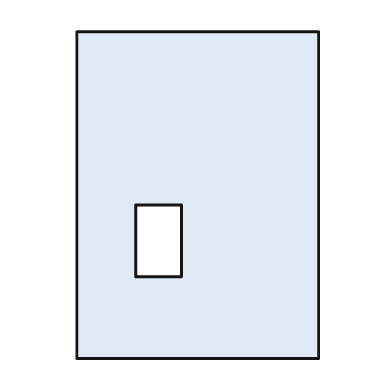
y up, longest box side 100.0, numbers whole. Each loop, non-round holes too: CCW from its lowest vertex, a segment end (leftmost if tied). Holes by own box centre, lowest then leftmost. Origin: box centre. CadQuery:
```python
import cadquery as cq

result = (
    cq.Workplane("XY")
    .moveTo(-37.0, -50.0)
    .lineTo(37.0, -50.0)
    .lineTo(37.0, 50.0)
    .lineTo(-37.0, 50.0)
    .close()
    .moveTo(-19.0, -25.0)
    .lineTo(-5.0, -25.0)
    .lineTo(-5.0, -3.0)
    .lineTo(-19.0, -3.0)
    .close()
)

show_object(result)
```